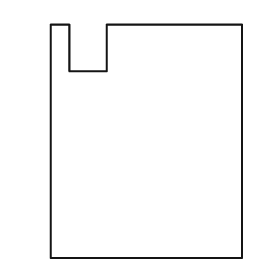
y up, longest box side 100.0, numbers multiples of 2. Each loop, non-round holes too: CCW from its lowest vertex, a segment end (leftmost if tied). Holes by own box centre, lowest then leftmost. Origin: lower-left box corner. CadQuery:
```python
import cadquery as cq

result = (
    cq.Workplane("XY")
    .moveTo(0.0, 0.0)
    .lineTo(82.0, 0.0)
    .lineTo(82.0, 100.0)
    .lineTo(24.0, 100.0)
    .lineTo(24.0, 80.0)
    .lineTo(8.0, 80.0)
    .lineTo(8.0, 100.0)
    .lineTo(0.0, 100.0)
    .close()
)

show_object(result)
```